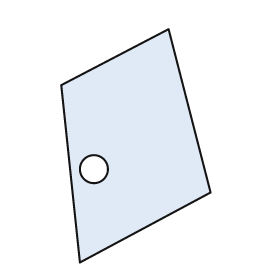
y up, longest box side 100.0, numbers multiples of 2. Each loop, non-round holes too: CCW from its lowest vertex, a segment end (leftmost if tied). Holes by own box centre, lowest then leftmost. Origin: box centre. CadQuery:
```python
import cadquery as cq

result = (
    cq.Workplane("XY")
    .moveTo(-24.0, -50.0)
    .lineTo(32.0, -20.0)
    .lineTo(14.0, 50.0)
    .lineTo(-32.0, 26.0)
    .close()
    .moveTo(-18.0, -10.0)
    .circle(6.0)
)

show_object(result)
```